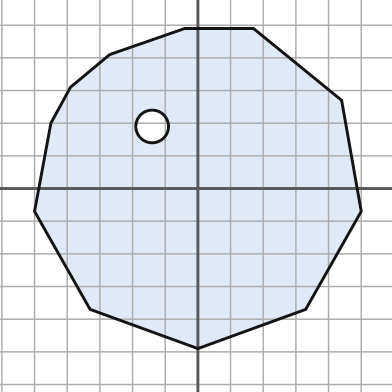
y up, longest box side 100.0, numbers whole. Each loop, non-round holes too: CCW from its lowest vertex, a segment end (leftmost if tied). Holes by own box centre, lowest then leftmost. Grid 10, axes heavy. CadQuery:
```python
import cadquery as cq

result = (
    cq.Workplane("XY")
    .moveTo(0.0, -49.0)
    .lineTo(33.0, -37.0)
    .lineTo(50.0, -7.0)
    .lineTo(44.0, 27.0)
    .lineTo(17.0, 49.0)
    .lineTo(-4.0, 49.0)
    .lineTo(-27.0, 41.0)
    .lineTo(-39.0, 31.0)
    .lineTo(-45.0, 20.0)
    .lineTo(-50.0, -7.0)
    .lineTo(-33.0, -37.0)
    .close()
    .moveTo(-14.0, 19.0)
    .circle(5.0)
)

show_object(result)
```